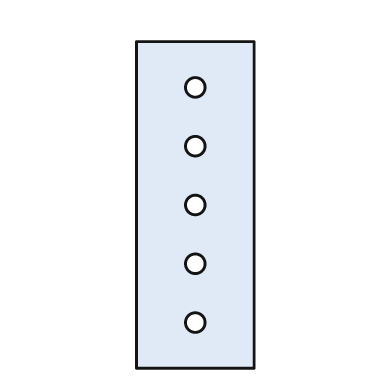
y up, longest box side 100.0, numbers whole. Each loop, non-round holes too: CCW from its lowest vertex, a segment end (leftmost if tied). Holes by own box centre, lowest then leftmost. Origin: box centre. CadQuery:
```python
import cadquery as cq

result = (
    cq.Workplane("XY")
    .moveTo(-18.0, -50.0)
    .lineTo(18.0, -50.0)
    .lineTo(18.0, 50.0)
    .lineTo(-18.0, 50.0)
    .close()
    .moveTo(0.0, -36.0)
    .circle(3.0)
    .moveTo(0.0, -18.0)
    .circle(3.0)
    .moveTo(0.0, 0.0)
    .circle(3.0)
    .moveTo(0.0, 18.0)
    .circle(3.0)
    .moveTo(0.0, 36.0)
    .circle(3.0)
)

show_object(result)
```